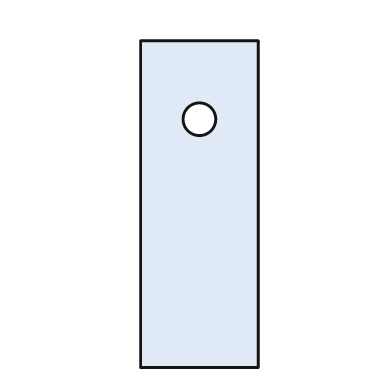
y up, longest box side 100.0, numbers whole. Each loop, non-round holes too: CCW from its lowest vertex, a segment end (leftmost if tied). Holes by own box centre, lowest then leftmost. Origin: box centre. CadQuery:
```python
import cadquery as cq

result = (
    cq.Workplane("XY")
    .moveTo(-18.0, -50.0)
    .lineTo(18.0, -50.0)
    .lineTo(18.0, 50.0)
    .lineTo(-18.0, 50.0)
    .close()
    .moveTo(0.0, 26.0)
    .circle(5.0)
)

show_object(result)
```